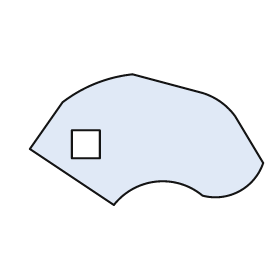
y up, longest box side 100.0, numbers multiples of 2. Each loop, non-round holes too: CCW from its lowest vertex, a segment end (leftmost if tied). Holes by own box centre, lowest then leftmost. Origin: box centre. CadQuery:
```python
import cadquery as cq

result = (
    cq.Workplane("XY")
    .moveTo(-14.0, -28.0)
    .threePointArc((4.0, -18.0), (24.0, -24.0))
    .threePointArc((40.0, -22.0), (50.0, -10.0))
    .lineTo(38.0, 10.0)
    .threePointArc((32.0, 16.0), (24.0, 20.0))
    .lineTo(-6.0, 28.0)
    .threePointArc((-22.0, 24.0), (-36.0, 16.0))
    .lineTo(-50.0, -4.0)
    .close()
    .moveTo(-32.0, -8.0)
    .lineTo(-20.0, -8.0)
    .lineTo(-20.0, 4.0)
    .lineTo(-32.0, 4.0)
    .close()
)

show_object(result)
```